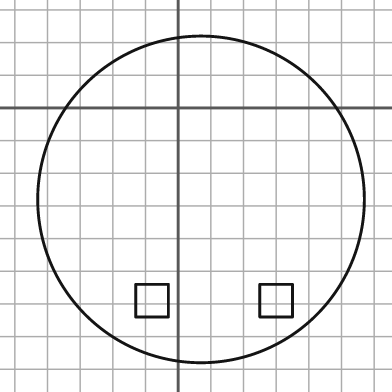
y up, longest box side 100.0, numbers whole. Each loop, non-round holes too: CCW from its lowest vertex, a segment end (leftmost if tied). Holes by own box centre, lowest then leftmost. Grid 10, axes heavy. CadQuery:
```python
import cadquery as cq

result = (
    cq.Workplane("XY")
    .moveTo(7.0, -28.0)
    .circle(50.0)
    .moveTo(-13.0, -64.0)
    .lineTo(-3.0, -64.0)
    .lineTo(-3.0, -54.0)
    .lineTo(-13.0, -54.0)
    .close()
    .moveTo(25.0, -64.0)
    .lineTo(35.0, -64.0)
    .lineTo(35.0, -54.0)
    .lineTo(25.0, -54.0)
    .close()
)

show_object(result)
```